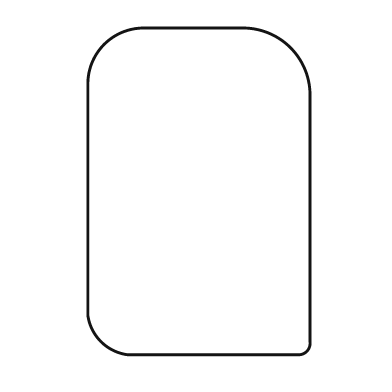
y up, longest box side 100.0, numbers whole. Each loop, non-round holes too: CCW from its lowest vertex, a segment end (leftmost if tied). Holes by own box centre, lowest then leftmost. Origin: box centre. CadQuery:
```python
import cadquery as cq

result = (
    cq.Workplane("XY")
    .moveTo(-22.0, -50.0)
    .lineTo(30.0, -50.0)
    .threePointArc((33.0, -49.0), (34.0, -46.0))
    .lineTo(34.0, 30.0)
    .threePointArc((28.0, 44.0), (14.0, 50.0))
    .lineTo(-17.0, 50.0)
    .threePointArc((-29.0, 45.0), (-34.0, 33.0))
    .lineTo(-34.0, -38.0)
    .threePointArc((-30.0, -46.0), (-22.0, -50.0))
    .close()
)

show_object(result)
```